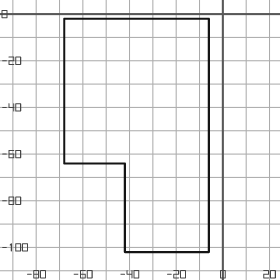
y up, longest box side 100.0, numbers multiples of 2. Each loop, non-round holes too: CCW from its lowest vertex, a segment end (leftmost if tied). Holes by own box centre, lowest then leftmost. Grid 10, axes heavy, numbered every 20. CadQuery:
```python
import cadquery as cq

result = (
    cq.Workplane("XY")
    .moveTo(-42.0, -102.0)
    .lineTo(-6.0, -102.0)
    .lineTo(-6.0, -2.0)
    .lineTo(-68.0, -2.0)
    .lineTo(-68.0, -64.0)
    .lineTo(-42.0, -64.0)
    .close()
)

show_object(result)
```